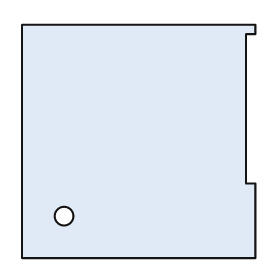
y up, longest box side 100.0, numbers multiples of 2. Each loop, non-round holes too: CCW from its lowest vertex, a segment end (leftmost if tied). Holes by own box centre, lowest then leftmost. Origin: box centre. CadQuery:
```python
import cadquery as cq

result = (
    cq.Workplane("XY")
    .moveTo(-50.0, -50.0)
    .lineTo(50.0, -50.0)
    .lineTo(50.0, -18.0)
    .lineTo(46.0, -18.0)
    .lineTo(46.0, 46.0)
    .lineTo(50.0, 46.0)
    .lineTo(50.0, 50.0)
    .lineTo(-50.0, 50.0)
    .close()
    .moveTo(-32.0, -32.0)
    .circle(4.0)
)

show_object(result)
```